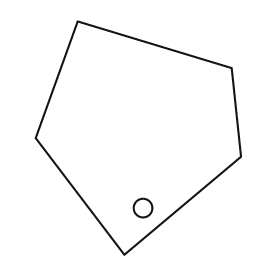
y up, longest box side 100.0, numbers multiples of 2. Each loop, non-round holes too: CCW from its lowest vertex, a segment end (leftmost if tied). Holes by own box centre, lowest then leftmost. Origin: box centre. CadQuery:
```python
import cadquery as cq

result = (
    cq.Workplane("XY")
    .moveTo(-6.0, -50.0)
    .lineTo(44.0, -8.0)
    .lineTo(40.0, 30.0)
    .lineTo(-26.0, 50.0)
    .lineTo(-44.0, 0.0)
    .close()
    .moveTo(2.0, -30.0)
    .circle(4.0)
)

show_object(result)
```